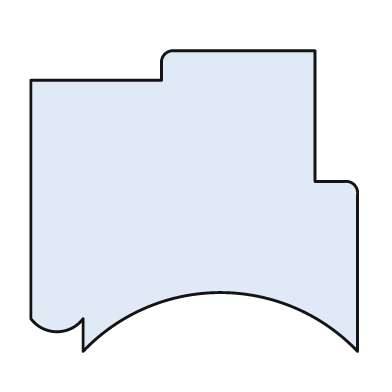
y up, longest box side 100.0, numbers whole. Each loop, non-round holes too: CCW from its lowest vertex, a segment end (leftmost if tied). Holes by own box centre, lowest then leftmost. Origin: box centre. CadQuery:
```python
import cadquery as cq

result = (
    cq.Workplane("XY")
    .moveTo(-34.0, -46.0)
    .threePointArc((8.0, -28.0), (50.0, -46.0))
    .lineTo(50.0, 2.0)
    .threePointArc((49.0, 5.0), (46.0, 6.0))
    .lineTo(37.0, 6.0)
    .lineTo(37.0, 46.0)
    .lineTo(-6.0, 46.0)
    .threePointArc((-9.0, 45.0), (-10.0, 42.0))
    .lineTo(-10.0, 37.0)
    .lineTo(-50.0, 37.0)
    .lineTo(-50.0, -36.0)
    .threePointArc((-42.0, -40.0), (-34.0, -36.0))
    .close()
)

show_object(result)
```